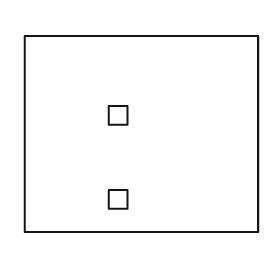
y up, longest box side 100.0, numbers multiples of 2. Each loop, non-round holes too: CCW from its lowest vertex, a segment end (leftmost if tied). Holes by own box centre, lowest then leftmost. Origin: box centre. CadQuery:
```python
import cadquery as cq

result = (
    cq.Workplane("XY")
    .moveTo(-50.0, -42.0)
    .lineTo(50.0, -42.0)
    .lineTo(50.0, 42.0)
    .lineTo(-50.0, 42.0)
    .close()
    .moveTo(-14.0, -32.0)
    .lineTo(-6.0, -32.0)
    .lineTo(-6.0, -24.0)
    .lineTo(-14.0, -24.0)
    .close()
    .moveTo(-14.0, 4.0)
    .lineTo(-6.0, 4.0)
    .lineTo(-6.0, 12.0)
    .lineTo(-14.0, 12.0)
    .close()
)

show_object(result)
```